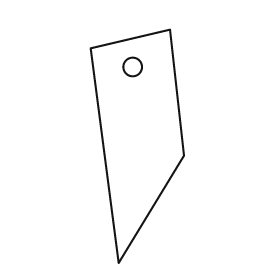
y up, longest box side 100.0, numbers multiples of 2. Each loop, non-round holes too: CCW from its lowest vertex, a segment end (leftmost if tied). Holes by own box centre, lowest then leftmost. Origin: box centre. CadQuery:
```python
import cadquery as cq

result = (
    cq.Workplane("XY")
    .moveTo(-8.0, -50.0)
    .lineTo(20.0, -4.0)
    .lineTo(14.0, 50.0)
    .lineTo(-20.0, 42.0)
    .close()
    .moveTo(-2.0, 34.0)
    .circle(4.0)
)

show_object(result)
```